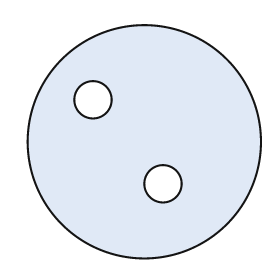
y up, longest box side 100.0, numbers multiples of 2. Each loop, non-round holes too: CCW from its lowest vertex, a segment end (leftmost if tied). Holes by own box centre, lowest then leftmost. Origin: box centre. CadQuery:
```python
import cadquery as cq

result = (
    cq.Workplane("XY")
    .moveTo(0.0, 0.0)
    .circle(50.0)
    .moveTo(8.0, -18.0)
    .circle(8.0)
    .moveTo(-22.0, 18.0)
    .circle(8.0)
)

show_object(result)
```